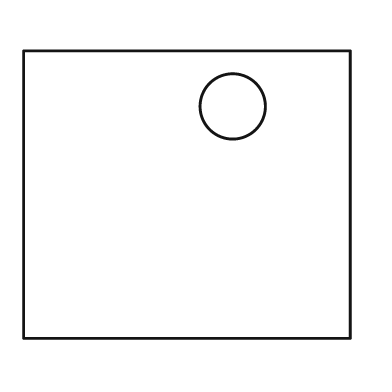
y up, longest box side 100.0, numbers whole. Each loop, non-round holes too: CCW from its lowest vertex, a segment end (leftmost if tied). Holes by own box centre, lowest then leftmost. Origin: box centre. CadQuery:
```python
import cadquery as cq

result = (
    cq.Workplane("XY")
    .moveTo(-50.0, -44.0)
    .lineTo(50.0, -44.0)
    .lineTo(50.0, 44.0)
    .lineTo(-50.0, 44.0)
    .close()
    .moveTo(14.0, 27.0)
    .circle(10.0)
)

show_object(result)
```